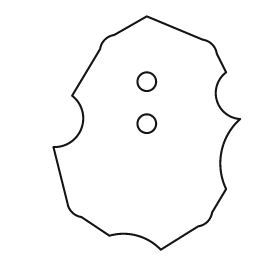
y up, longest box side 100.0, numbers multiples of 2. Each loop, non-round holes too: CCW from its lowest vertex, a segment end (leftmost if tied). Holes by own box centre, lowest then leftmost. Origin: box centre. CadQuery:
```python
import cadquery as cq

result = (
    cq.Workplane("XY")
    .moveTo(6.0, -50.0)
    .lineTo(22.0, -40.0)
    .threePointArc((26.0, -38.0), (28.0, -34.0))
    .lineTo(34.0, -24.0)
    .threePointArc((32.0, -8.0), (40.0, 6.0))
    .threePointArc((30.0, 14.0), (34.0, 26.0))
    .lineTo(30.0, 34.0)
    .threePointArc((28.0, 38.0), (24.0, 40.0))
    .lineTo(0.0, 50.0)
    .lineTo(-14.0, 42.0)
    .threePointArc((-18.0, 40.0), (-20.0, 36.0))
    .lineTo(-32.0, 16.0)
    .threePointArc((-28.0, 2.0), (-40.0, -6.0))
    .lineTo(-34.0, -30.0)
    .threePointArc((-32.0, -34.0), (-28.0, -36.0))
    .lineTo(-16.0, -44.0)
    .threePointArc((-4.0, -44.0), (6.0, -50.0))
    .close()
    .moveTo(0.0, 4.0)
    .circle(4.0)
    .moveTo(0.0, 22.0)
    .circle(4.0)
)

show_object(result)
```